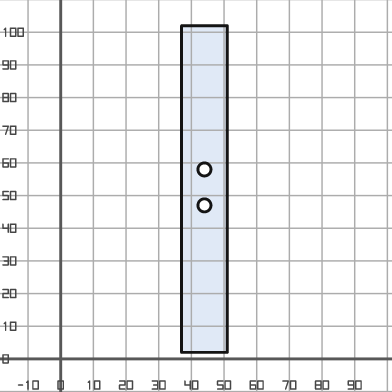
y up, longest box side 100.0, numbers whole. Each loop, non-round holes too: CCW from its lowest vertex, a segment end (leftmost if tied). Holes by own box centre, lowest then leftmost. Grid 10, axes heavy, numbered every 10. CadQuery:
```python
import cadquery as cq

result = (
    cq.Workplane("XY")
    .moveTo(37.0, 2.0)
    .lineTo(51.0, 2.0)
    .lineTo(51.0, 102.0)
    .lineTo(37.0, 102.0)
    .close()
    .moveTo(44.0, 47.0)
    .circle(2.0)
    .moveTo(44.0, 58.0)
    .circle(2.0)
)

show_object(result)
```